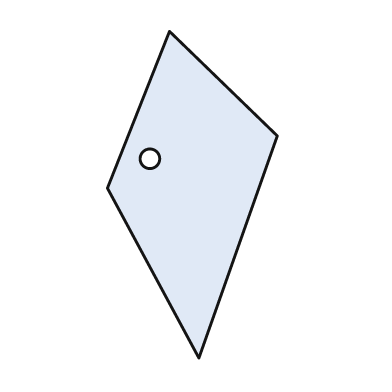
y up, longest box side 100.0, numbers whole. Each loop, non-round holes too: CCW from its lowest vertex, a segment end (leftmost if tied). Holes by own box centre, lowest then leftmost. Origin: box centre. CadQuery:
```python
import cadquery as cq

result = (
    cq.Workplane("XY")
    .moveTo(2.0, -50.0)
    .lineTo(26.0, 18.0)
    .lineTo(-7.0, 50.0)
    .lineTo(-26.0, 2.0)
    .close()
    .moveTo(-13.0, 11.0)
    .circle(3.0)
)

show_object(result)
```